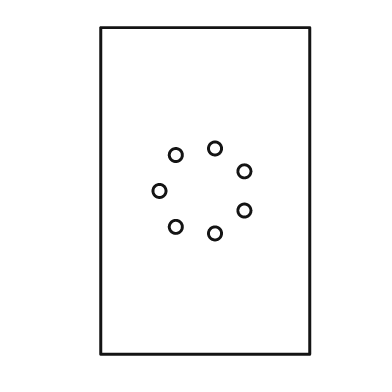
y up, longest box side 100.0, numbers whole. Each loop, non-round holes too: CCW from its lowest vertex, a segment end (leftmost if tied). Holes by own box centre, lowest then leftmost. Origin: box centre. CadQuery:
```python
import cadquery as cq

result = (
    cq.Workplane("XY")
    .moveTo(-32.0, -50.0)
    .lineTo(32.0, -50.0)
    .lineTo(32.0, 50.0)
    .lineTo(-32.0, 50.0)
    .close()
    .moveTo(3.0, -13.0)
    .circle(2.0)
    .moveTo(-9.0, -11.0)
    .circle(2.0)
    .moveTo(12.0, -6.0)
    .circle(2.0)
    .moveTo(-14.0, 0.0)
    .circle(2.0)
    .moveTo(12.0, 6.0)
    .circle(2.0)
    .moveTo(-9.0, 11.0)
    .circle(2.0)
    .moveTo(3.0, 13.0)
    .circle(2.0)
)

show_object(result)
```